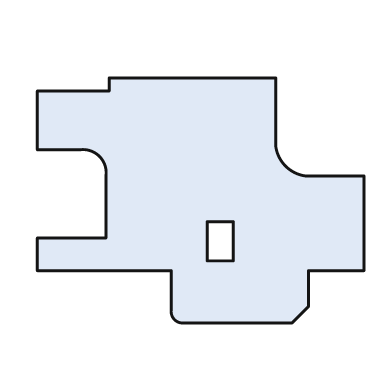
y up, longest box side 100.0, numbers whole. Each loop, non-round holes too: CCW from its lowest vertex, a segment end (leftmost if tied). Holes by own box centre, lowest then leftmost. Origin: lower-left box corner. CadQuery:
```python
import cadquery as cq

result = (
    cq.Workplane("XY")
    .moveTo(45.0, 0.0)
    .lineTo(78.0, 0.0)
    .lineTo(83.0, 5.0)
    .lineTo(83.0, 16.0)
    .lineTo(100.0, 16.0)
    .lineTo(100.0, 45.0)
    .lineTo(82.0, 45.0)
    .threePointArc((76.0, 48.0), (73.0, 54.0))
    .lineTo(73.0, 75.0)
    .lineTo(22.0, 75.0)
    .lineTo(22.0, 71.0)
    .lineTo(0.0, 71.0)
    .lineTo(0.0, 53.0)
    .lineTo(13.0, 53.0)
    .threePointArc((19.0, 51.0), (21.0, 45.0))
    .lineTo(21.0, 26.0)
    .lineTo(0.0, 26.0)
    .lineTo(0.0, 16.0)
    .lineTo(41.0, 16.0)
    .lineTo(41.0, 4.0)
    .threePointArc((42.0, 1.0), (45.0, 0.0))
    .close()
    .moveTo(52.0, 19.0)
    .lineTo(60.0, 19.0)
    .lineTo(60.0, 31.0)
    .lineTo(52.0, 31.0)
    .close()
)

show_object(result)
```